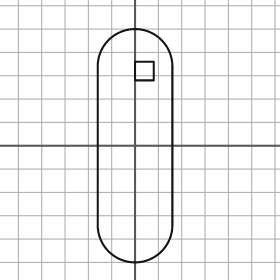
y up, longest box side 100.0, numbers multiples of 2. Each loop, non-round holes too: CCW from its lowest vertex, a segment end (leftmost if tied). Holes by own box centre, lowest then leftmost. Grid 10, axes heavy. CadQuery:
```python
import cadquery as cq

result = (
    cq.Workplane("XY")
    .moveTo(-16.0, -34.0)
    .threePointArc((0.0, -50.0), (16.0, -34.0))
    .lineTo(16.0, 34.0)
    .threePointArc((0.0, 50.0), (-16.0, 34.0))
    .close()
    .moveTo(0.0, 28.0)
    .lineTo(8.0, 28.0)
    .lineTo(8.0, 36.0)
    .lineTo(0.0, 36.0)
    .close()
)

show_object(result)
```